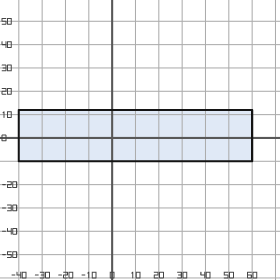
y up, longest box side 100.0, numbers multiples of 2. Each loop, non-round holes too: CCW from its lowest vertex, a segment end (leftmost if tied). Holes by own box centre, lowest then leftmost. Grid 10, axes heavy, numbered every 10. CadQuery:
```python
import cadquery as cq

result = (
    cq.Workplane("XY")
    .moveTo(-40.0, -10.0)
    .lineTo(60.0, -10.0)
    .lineTo(60.0, 12.0)
    .lineTo(-40.0, 12.0)
    .close()
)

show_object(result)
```